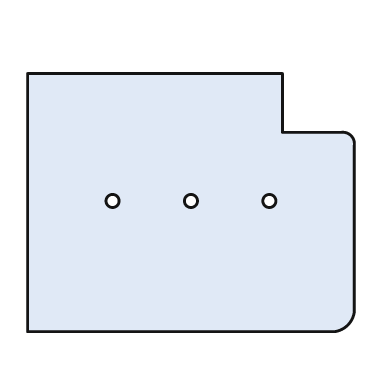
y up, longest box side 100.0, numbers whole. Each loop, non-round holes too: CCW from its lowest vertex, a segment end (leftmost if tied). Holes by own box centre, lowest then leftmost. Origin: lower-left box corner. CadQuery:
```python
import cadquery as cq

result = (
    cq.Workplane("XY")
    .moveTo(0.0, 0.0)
    .lineTo(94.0, 0.0)
    .threePointArc((98.0, 2.0), (100.0, 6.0))
    .lineTo(100.0, 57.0)
    .threePointArc((99.0, 60.0), (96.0, 61.0))
    .lineTo(78.0, 61.0)
    .lineTo(78.0, 79.0)
    .lineTo(0.0, 79.0)
    .close()
    .moveTo(26.0, 40.0)
    .circle(2.0)
    .moveTo(50.0, 40.0)
    .circle(2.0)
    .moveTo(74.0, 40.0)
    .circle(2.0)
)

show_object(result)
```